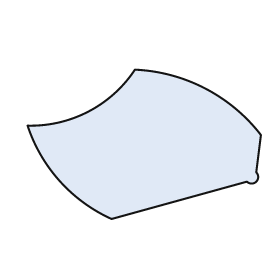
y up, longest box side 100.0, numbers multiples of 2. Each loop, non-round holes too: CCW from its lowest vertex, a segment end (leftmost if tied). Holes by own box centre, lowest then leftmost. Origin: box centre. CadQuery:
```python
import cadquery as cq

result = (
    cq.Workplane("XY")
    .moveTo(-14.0, -32.0)
    .lineTo(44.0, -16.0)
    .threePointArc((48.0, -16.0), (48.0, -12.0))
    .lineTo(50.0, 4.0)
    .threePointArc((26.0, 24.0), (-4.0, 32.0))
    .threePointArc((-24.0, 14.0), (-50.0, 8.0))
    .threePointArc((-36.0, -16.0), (-14.0, -32.0))
    .close()
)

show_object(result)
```